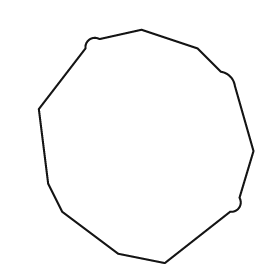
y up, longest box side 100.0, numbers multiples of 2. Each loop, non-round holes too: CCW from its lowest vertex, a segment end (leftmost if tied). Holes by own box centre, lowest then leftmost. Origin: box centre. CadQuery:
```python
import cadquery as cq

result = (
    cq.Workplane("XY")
    .moveTo(8.0, -50.0)
    .lineTo(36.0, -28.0)
    .threePointArc((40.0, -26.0), (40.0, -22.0))
    .lineTo(46.0, -2.0)
    .lineTo(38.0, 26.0)
    .threePointArc((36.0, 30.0), (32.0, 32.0))
    .lineTo(22.0, 42.0)
    .lineTo(-2.0, 50.0)
    .lineTo(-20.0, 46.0)
    .threePointArc((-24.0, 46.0), (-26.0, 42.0))
    .lineTo(-46.0, 16.0)
    .lineTo(-42.0, -16.0)
    .lineTo(-36.0, -28.0)
    .lineTo(-12.0, -46.0)
    .close()
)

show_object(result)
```